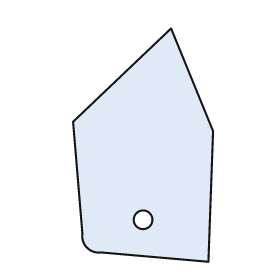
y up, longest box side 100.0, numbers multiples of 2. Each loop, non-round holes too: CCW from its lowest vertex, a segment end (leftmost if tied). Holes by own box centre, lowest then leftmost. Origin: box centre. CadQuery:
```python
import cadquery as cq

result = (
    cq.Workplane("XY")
    .moveTo(28.0, -50.0)
    .lineTo(30.0, 6.0)
    .lineTo(12.0, 50.0)
    .lineTo(-30.0, 10.0)
    .lineTo(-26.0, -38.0)
    .threePointArc((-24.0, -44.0), (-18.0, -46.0))
    .close()
    .moveTo(0.0, -32.0)
    .circle(4.0)
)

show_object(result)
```